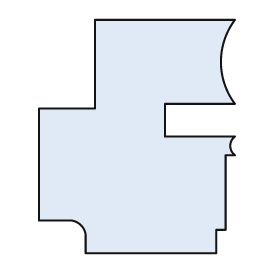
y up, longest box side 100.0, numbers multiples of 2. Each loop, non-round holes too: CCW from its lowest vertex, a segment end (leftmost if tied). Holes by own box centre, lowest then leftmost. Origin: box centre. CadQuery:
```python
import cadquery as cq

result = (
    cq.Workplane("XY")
    .moveTo(-22.0, -50.0)
    .lineTo(34.0, -50.0)
    .lineTo(34.0, -40.0)
    .lineTo(38.0, -40.0)
    .lineTo(38.0, -8.0)
    .lineTo(42.0, -8.0)
    .threePointArc((40.0, -4.0), (42.0, 0.0))
    .lineTo(12.0, 0.0)
    .lineTo(12.0, 14.0)
    .lineTo(42.0, 14.0)
    .threePointArc((36.0, 32.0), (42.0, 50.0))
    .lineTo(-18.0, 50.0)
    .lineTo(-18.0, 12.0)
    .lineTo(-42.0, 12.0)
    .lineTo(-42.0, -36.0)
    .lineTo(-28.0, -36.0)
    .threePointArc((-24.0, -38.0), (-22.0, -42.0))
    .close()
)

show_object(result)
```